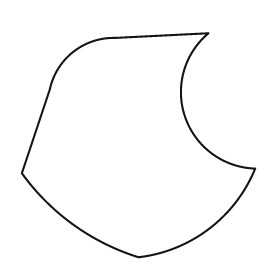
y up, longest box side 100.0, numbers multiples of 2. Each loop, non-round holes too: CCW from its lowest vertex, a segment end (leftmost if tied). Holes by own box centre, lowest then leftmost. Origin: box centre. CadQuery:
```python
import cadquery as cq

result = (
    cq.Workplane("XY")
    .moveTo(0.0, -48.0)
    .threePointArc((30.0, -36.0), (50.0, -10.0))
    .threePointArc((20.0, 12.0), (30.0, 48.0))
    .lineTo(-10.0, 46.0)
    .threePointArc((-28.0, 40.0), (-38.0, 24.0))
    .lineTo(-50.0, -12.0)
    .threePointArc((-28.0, -34.0), (0.0, -48.0))
    .close()
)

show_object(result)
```